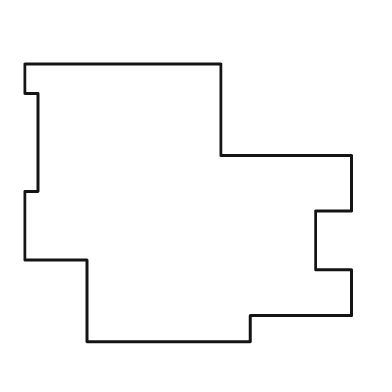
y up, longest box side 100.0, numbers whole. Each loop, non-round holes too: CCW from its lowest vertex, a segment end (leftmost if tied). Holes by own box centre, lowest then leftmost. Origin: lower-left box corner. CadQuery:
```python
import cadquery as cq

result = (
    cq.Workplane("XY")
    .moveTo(19.0, 0.0)
    .lineTo(69.0, 0.0)
    .lineTo(69.0, 8.0)
    .lineTo(100.0, 8.0)
    .lineTo(100.0, 22.0)
    .lineTo(89.0, 22.0)
    .lineTo(89.0, 40.0)
    .lineTo(100.0, 40.0)
    .lineTo(100.0, 57.0)
    .lineTo(60.0, 57.0)
    .lineTo(60.0, 85.0)
    .lineTo(0.0, 85.0)
    .lineTo(0.0, 76.0)
    .lineTo(4.0, 76.0)
    .lineTo(4.0, 46.0)
    .lineTo(0.0, 46.0)
    .lineTo(0.0, 25.0)
    .lineTo(19.0, 25.0)
    .close()
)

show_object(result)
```